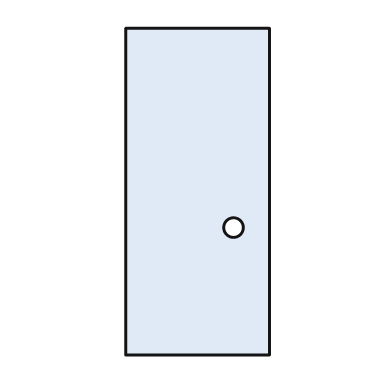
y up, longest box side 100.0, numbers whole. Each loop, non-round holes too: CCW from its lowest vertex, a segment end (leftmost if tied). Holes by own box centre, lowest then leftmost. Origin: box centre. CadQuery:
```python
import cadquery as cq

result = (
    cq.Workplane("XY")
    .moveTo(-22.0, -50.0)
    .lineTo(22.0, -50.0)
    .lineTo(22.0, 50.0)
    .lineTo(-22.0, 50.0)
    .close()
    .moveTo(11.0, -11.0)
    .circle(3.0)
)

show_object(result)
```